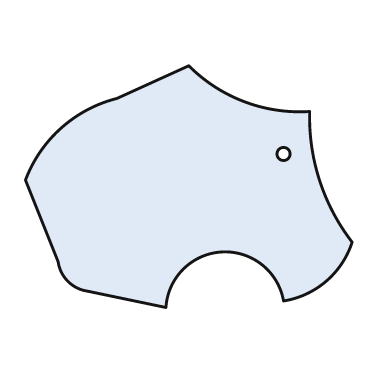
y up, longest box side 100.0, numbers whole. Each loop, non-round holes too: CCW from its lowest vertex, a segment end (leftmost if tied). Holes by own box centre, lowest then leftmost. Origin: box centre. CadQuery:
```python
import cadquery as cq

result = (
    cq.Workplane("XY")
    .moveTo(-7.0, -37.0)
    .threePointArc((10.0, -20.0), (29.0, -35.0))
    .threePointArc((42.0, -29.0), (50.0, -17.0))
    .threePointArc((40.0, 2.0), (37.0, 23.0))
    .threePointArc((17.0, 26.0), (0.0, 37.0))
    .lineTo(-22.0, 27.0)
    .threePointArc((-39.0, 18.0), (-50.0, 2.0))
    .lineTo(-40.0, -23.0)
    .threePointArc((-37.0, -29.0), (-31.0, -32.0))
    .close()
    .moveTo(29.0, 10.0)
    .circle(2.0)
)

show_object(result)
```